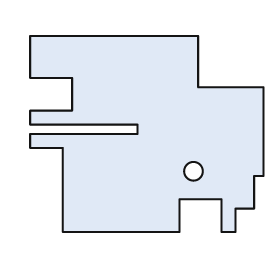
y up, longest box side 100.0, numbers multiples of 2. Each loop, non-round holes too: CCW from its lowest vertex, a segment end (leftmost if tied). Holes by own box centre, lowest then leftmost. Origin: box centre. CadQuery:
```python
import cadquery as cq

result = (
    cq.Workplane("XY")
    .moveTo(-36.0, -42.0)
    .lineTo(14.0, -42.0)
    .lineTo(14.0, -28.0)
    .lineTo(32.0, -28.0)
    .lineTo(32.0, -42.0)
    .lineTo(38.0, -42.0)
    .lineTo(38.0, -32.0)
    .lineTo(46.0, -32.0)
    .lineTo(46.0, -18.0)
    .lineTo(50.0, -18.0)
    .lineTo(50.0, 20.0)
    .lineTo(22.0, 20.0)
    .lineTo(22.0, 42.0)
    .lineTo(-50.0, 42.0)
    .lineTo(-50.0, 24.0)
    .lineTo(-32.0, 24.0)
    .lineTo(-32.0, 10.0)
    .lineTo(-50.0, 10.0)
    .lineTo(-50.0, 4.0)
    .lineTo(-4.0, 4.0)
    .lineTo(-4.0, 0.0)
    .lineTo(-50.0, 0.0)
    .lineTo(-50.0, -6.0)
    .lineTo(-36.0, -6.0)
    .close()
    .moveTo(20.0, -16.0)
    .circle(4.0)
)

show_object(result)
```